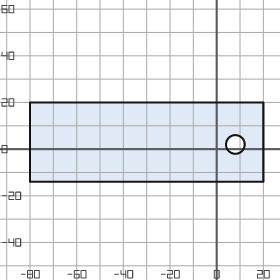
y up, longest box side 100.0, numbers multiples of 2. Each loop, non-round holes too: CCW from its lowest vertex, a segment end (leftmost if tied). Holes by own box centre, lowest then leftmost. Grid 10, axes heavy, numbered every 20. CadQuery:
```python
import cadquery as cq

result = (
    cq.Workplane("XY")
    .moveTo(-80.0, -14.0)
    .lineTo(20.0, -14.0)
    .lineTo(20.0, 20.0)
    .lineTo(-80.0, 20.0)
    .close()
    .moveTo(8.0, 2.0)
    .circle(4.0)
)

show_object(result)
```